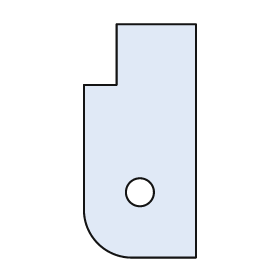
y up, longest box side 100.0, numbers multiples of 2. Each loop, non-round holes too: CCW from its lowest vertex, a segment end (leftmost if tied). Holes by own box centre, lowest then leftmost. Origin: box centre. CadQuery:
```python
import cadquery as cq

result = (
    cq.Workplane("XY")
    .moveTo(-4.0, -50.0)
    .lineTo(24.0, -50.0)
    .lineTo(24.0, 50.0)
    .lineTo(-10.0, 50.0)
    .lineTo(-10.0, 24.0)
    .lineTo(-24.0, 24.0)
    .lineTo(-24.0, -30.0)
    .threePointArc((-18.0, -44.0), (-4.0, -50.0))
    .close()
    .moveTo(0.0, -22.0)
    .circle(6.0)
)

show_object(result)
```